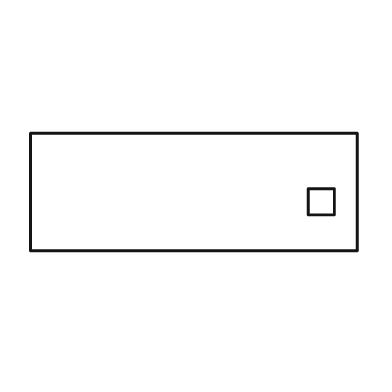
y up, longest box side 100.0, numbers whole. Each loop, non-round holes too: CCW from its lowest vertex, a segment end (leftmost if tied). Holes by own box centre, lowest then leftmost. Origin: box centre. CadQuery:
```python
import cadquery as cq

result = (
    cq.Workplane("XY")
    .moveTo(-50.0, -18.0)
    .lineTo(50.0, -18.0)
    .lineTo(50.0, 18.0)
    .lineTo(-50.0, 18.0)
    .close()
    .moveTo(35.0, -7.0)
    .lineTo(43.0, -7.0)
    .lineTo(43.0, 1.0)
    .lineTo(35.0, 1.0)
    .close()
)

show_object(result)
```